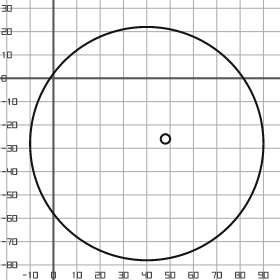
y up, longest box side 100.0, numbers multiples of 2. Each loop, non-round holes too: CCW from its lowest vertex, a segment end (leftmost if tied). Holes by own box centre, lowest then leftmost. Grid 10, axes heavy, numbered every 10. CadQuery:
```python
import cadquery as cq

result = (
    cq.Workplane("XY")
    .moveTo(40.0, -28.0)
    .circle(50.0)
    .moveTo(48.0, -26.0)
    .circle(2.0)
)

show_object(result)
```